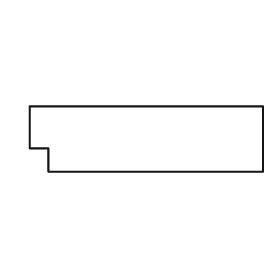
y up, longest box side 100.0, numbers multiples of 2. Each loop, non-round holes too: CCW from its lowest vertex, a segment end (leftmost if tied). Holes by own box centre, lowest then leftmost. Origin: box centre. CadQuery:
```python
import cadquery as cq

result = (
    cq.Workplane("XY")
    .moveTo(-42.0, -14.0)
    .lineTo(50.0, -14.0)
    .lineTo(50.0, 14.0)
    .lineTo(-50.0, 14.0)
    .lineTo(-50.0, -4.0)
    .lineTo(-42.0, -4.0)
    .close()
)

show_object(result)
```